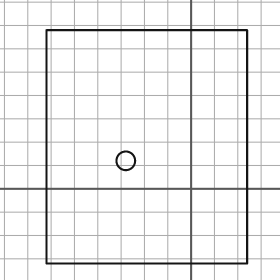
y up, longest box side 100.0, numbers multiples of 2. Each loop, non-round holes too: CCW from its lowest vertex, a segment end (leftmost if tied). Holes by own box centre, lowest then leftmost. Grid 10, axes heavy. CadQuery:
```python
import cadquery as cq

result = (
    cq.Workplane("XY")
    .moveTo(-62.0, -32.0)
    .lineTo(24.0, -32.0)
    .lineTo(24.0, 68.0)
    .lineTo(-62.0, 68.0)
    .close()
    .moveTo(-28.0, 12.0)
    .circle(4.0)
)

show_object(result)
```